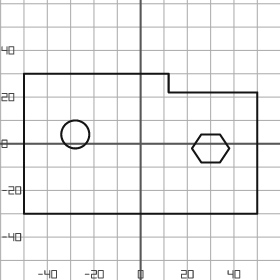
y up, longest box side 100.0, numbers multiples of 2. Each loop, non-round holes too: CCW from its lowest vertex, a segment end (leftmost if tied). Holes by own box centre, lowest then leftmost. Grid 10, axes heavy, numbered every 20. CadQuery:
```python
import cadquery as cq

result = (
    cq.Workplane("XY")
    .moveTo(-50.0, -30.0)
    .lineTo(50.0, -30.0)
    .lineTo(50.0, 22.0)
    .lineTo(12.0, 22.0)
    .lineTo(12.0, 30.0)
    .lineTo(-50.0, 30.0)
    .close()
    .moveTo(26.0, -8.0)
    .lineTo(34.0, -8.0)
    .lineTo(38.0, -2.0)
    .lineTo(34.0, 4.0)
    .lineTo(26.0, 4.0)
    .lineTo(22.0, -2.0)
    .close()
    .moveTo(-28.0, 4.0)
    .circle(6.0)
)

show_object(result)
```